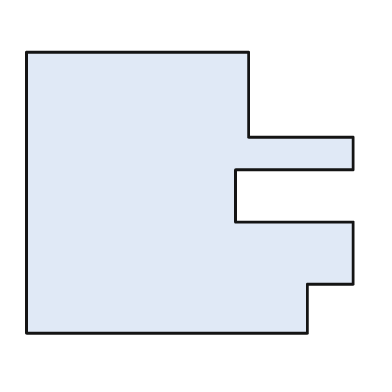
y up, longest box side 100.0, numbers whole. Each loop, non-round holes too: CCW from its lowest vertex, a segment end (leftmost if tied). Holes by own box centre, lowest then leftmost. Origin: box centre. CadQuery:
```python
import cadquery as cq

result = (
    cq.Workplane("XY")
    .moveTo(-50.0, -43.0)
    .lineTo(36.0, -43.0)
    .lineTo(36.0, -28.0)
    .lineTo(50.0, -28.0)
    .lineTo(50.0, -9.0)
    .lineTo(14.0, -9.0)
    .lineTo(14.0, 7.0)
    .lineTo(50.0, 7.0)
    .lineTo(50.0, 17.0)
    .lineTo(18.0, 17.0)
    .lineTo(18.0, 43.0)
    .lineTo(-50.0, 43.0)
    .close()
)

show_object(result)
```